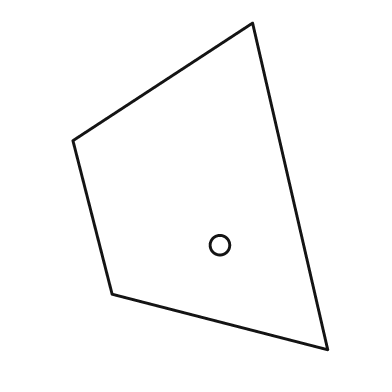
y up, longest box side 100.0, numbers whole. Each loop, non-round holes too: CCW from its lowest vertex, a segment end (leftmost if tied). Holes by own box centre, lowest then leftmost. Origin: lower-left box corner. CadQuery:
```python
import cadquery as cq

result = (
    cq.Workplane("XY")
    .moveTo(78.0, 0.0)
    .lineTo(55.0, 100.0)
    .lineTo(0.0, 64.0)
    .lineTo(12.0, 17.0)
    .close()
    .moveTo(45.0, 32.0)
    .circle(3.0)
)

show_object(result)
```